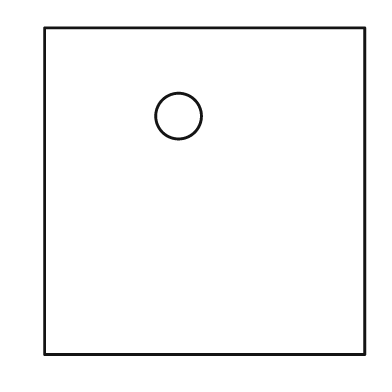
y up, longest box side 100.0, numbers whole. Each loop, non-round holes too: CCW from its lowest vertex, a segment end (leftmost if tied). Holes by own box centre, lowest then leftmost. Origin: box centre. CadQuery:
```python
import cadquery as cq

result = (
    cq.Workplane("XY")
    .moveTo(-49.0, -50.0)
    .lineTo(49.0, -50.0)
    .lineTo(49.0, 50.0)
    .lineTo(-49.0, 50.0)
    .close()
    .moveTo(-8.0, 23.0)
    .circle(7.0)
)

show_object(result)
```